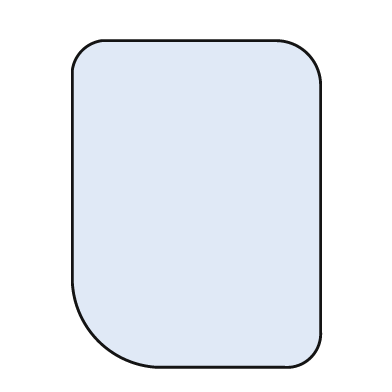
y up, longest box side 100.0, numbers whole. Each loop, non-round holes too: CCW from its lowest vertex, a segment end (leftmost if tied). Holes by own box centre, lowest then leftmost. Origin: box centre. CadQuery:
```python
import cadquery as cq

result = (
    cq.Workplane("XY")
    .moveTo(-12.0, -50.0)
    .lineTo(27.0, -50.0)
    .threePointArc((35.0, -47.0), (38.0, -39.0))
    .lineTo(38.0, 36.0)
    .threePointArc((34.0, 46.0), (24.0, 50.0))
    .lineTo(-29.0, 50.0)
    .threePointArc((-35.0, 47.0), (-38.0, 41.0))
    .lineTo(-38.0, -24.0)
    .threePointArc((-30.0, -42.0), (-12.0, -50.0))
    .close()
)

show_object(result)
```